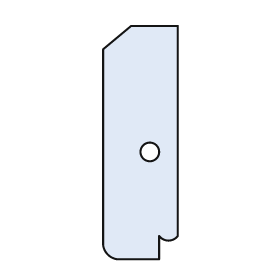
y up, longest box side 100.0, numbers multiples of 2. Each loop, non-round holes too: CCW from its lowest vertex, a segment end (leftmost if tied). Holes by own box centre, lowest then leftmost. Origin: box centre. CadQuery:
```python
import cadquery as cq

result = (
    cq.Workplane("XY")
    .moveTo(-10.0, -50.0)
    .lineTo(8.0, -50.0)
    .lineTo(8.0, -40.0)
    .threePointArc((12.0, -42.0), (16.0, -40.0))
    .lineTo(16.0, 50.0)
    .lineTo(-4.0, 50.0)
    .lineTo(-16.0, 40.0)
    .lineTo(-16.0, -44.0)
    .threePointArc((-14.0, -48.0), (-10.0, -50.0))
    .close()
    .moveTo(4.0, -4.0)
    .circle(4.0)
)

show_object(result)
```